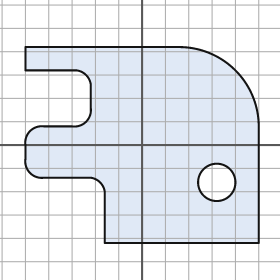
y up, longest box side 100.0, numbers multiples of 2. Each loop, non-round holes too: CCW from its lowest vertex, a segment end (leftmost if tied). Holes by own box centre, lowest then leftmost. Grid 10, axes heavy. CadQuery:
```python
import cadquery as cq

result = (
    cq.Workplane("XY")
    .moveTo(-16.0, -42.0)
    .lineTo(50.0, -42.0)
    .lineTo(50.0, 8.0)
    .threePointArc((40.0, 32.0), (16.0, 42.0))
    .lineTo(-50.0, 42.0)
    .lineTo(-50.0, 32.0)
    .lineTo(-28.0, 32.0)
    .threePointArc((-24.0, 30.0), (-22.0, 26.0))
    .lineTo(-22.0, 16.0)
    .threePointArc((-24.0, 10.0), (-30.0, 8.0))
    .lineTo(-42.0, 8.0)
    .threePointArc((-48.0, 6.0), (-50.0, 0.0))
    .lineTo(-50.0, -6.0)
    .threePointArc((-48.0, -12.0), (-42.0, -14.0))
    .lineTo(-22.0, -14.0)
    .threePointArc((-18.0, -16.0), (-16.0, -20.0))
    .close()
    .moveTo(32.0, -16.0)
    .circle(8.0)
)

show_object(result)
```